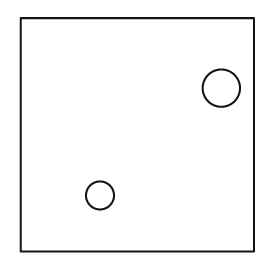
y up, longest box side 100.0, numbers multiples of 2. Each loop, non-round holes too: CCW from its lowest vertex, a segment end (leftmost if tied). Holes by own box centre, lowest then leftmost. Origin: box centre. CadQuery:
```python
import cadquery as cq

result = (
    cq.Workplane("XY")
    .moveTo(-50.0, -50.0)
    .lineTo(50.0, -50.0)
    .lineTo(50.0, 50.0)
    .lineTo(-50.0, 50.0)
    .close()
    .moveTo(-16.0, -26.0)
    .circle(6.0)
    .moveTo(36.0, 20.0)
    .circle(8.0)
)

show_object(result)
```